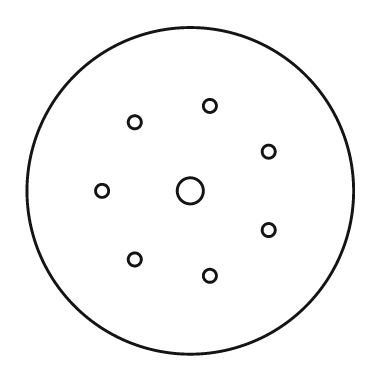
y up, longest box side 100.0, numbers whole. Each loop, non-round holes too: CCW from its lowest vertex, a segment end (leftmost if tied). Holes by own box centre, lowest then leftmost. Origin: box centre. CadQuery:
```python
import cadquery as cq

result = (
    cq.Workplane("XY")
    .moveTo(0.0, 0.0)
    .circle(50.0)
    .moveTo(6.0, -26.0)
    .circle(2.0)
    .moveTo(-17.0, -21.0)
    .circle(2.0)
    .moveTo(24.0, -12.0)
    .circle(2.0)
    .moveTo(-27.0, 0.0)
    .circle(2.0)
    .moveTo(0.0, 0.0)
    .circle(4.0)
    .moveTo(24.0, 12.0)
    .circle(2.0)
    .moveTo(-17.0, 21.0)
    .circle(2.0)
    .moveTo(6.0, 26.0)
    .circle(2.0)
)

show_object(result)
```